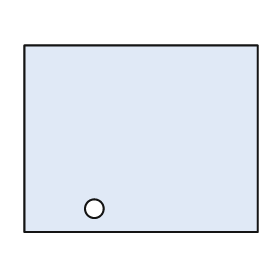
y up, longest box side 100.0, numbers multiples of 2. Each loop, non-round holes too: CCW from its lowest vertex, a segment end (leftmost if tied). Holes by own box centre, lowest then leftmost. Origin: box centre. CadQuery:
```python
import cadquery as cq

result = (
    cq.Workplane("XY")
    .moveTo(-50.0, -40.0)
    .lineTo(50.0, -40.0)
    .lineTo(50.0, 40.0)
    .lineTo(-50.0, 40.0)
    .close()
    .moveTo(-20.0, -30.0)
    .circle(4.0)
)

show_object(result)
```